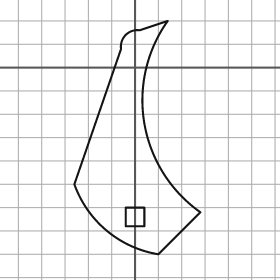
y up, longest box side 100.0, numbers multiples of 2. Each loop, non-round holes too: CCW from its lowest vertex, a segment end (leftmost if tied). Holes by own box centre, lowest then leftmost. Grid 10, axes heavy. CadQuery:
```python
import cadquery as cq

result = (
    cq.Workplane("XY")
    .moveTo(10.0, -80.0)
    .lineTo(28.0, -62.0)
    .threePointArc((4.0, -24.0), (14.0, 20.0))
    .lineTo(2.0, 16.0)
    .threePointArc((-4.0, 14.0), (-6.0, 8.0))
    .lineTo(-26.0, -50.0)
    .threePointArc((-12.0, -70.0), (10.0, -80.0))
    .close()
    .moveTo(-4.0, -68.0)
    .lineTo(4.0, -68.0)
    .lineTo(4.0, -60.0)
    .lineTo(-4.0, -60.0)
    .close()
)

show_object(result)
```